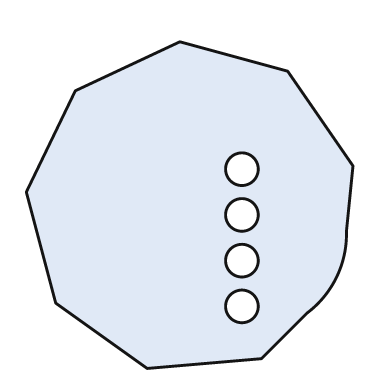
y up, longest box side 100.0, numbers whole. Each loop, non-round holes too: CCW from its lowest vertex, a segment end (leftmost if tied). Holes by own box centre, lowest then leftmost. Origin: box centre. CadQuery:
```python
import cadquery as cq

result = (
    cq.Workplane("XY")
    .moveTo(-13.0, -50.0)
    .lineTo(22.0, -47.0)
    .lineTo(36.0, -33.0)
    .threePointArc((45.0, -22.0), (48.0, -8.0))
    .lineTo(50.0, 12.0)
    .lineTo(30.0, 41.0)
    .lineTo(-3.0, 50.0)
    .lineTo(-35.0, 35.0)
    .lineTo(-50.0, 4.0)
    .lineTo(-41.0, -30.0)
    .close()
    .moveTo(16.0, -31.0)
    .circle(5.0)
    .moveTo(16.0, -17.0)
    .circle(5.0)
    .moveTo(16.0, -3.0)
    .circle(5.0)
    .moveTo(16.0, 11.0)
    .circle(5.0)
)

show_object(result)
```